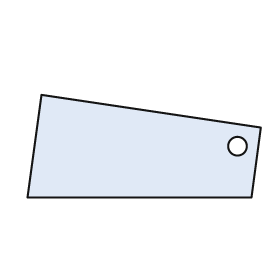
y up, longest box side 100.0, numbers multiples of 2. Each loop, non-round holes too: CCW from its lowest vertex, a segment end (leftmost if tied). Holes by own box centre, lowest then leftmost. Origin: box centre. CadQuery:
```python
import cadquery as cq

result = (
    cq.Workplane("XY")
    .moveTo(-50.0, -22.0)
    .lineTo(46.0, -22.0)
    .lineTo(50.0, 8.0)
    .lineTo(-44.0, 22.0)
    .close()
    .moveTo(40.0, 0.0)
    .circle(4.0)
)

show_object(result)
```